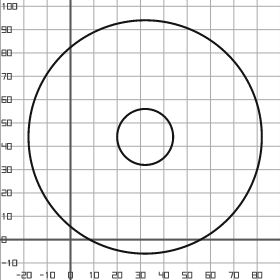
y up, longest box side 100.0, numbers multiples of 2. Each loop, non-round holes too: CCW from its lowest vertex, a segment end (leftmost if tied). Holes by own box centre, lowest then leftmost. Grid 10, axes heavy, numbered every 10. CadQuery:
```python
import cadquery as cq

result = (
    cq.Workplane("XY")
    .moveTo(32.0, 44.0)
    .circle(50.0)
    .moveTo(32.0, 44.0)
    .circle(12.0)
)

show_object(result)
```